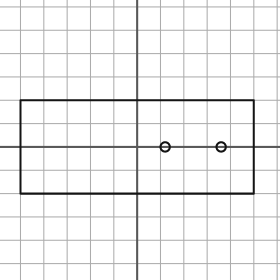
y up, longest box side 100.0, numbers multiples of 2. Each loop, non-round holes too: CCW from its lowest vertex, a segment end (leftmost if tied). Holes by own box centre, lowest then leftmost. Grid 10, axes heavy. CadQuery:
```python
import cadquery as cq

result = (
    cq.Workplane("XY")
    .moveTo(-50.0, -20.0)
    .lineTo(50.0, -20.0)
    .lineTo(50.0, 20.0)
    .lineTo(-50.0, 20.0)
    .close()
    .moveTo(12.0, 0.0)
    .circle(2.0)
    .moveTo(36.0, 0.0)
    .circle(2.0)
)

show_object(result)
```